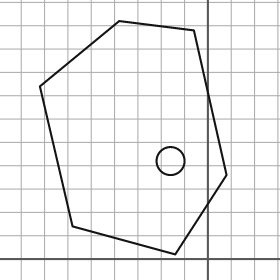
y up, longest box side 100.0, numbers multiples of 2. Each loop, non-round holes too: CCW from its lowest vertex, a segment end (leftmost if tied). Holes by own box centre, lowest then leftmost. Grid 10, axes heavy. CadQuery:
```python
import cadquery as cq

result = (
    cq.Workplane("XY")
    .moveTo(-14.0, 2.0)
    .lineTo(8.0, 36.0)
    .lineTo(-6.0, 98.0)
    .lineTo(-38.0, 102.0)
    .lineTo(-72.0, 74.0)
    .lineTo(-58.0, 14.0)
    .close()
    .moveTo(-16.0, 42.0)
    .circle(6.0)
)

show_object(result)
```